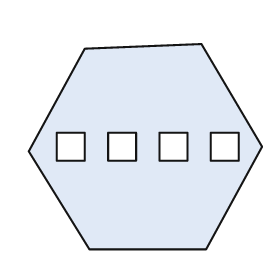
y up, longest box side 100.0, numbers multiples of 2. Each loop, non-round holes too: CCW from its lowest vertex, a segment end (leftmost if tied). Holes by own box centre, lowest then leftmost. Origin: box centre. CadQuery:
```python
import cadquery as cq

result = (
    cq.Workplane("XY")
    .moveTo(-24.0, -44.0)
    .lineTo(26.0, -44.0)
    .lineTo(50.0, 0.0)
    .lineTo(24.0, 44.0)
    .lineTo(-26.0, 42.0)
    .lineTo(-50.0, -2.0)
    .close()
    .moveTo(-38.0, -6.0)
    .lineTo(-26.0, -6.0)
    .lineTo(-26.0, 6.0)
    .lineTo(-38.0, 6.0)
    .close()
    .moveTo(-16.0, -6.0)
    .lineTo(-4.0, -6.0)
    .lineTo(-4.0, 6.0)
    .lineTo(-16.0, 6.0)
    .close()
    .moveTo(6.0, -6.0)
    .lineTo(18.0, -6.0)
    .lineTo(18.0, 6.0)
    .lineTo(6.0, 6.0)
    .close()
    .moveTo(28.0, -6.0)
    .lineTo(40.0, -6.0)
    .lineTo(40.0, 6.0)
    .lineTo(28.0, 6.0)
    .close()
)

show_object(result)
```